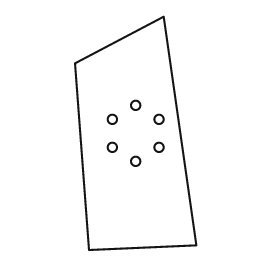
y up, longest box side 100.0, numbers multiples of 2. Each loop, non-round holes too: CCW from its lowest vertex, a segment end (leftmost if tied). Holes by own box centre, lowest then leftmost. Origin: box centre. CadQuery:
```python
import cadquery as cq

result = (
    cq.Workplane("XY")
    .moveTo(-20.0, -50.0)
    .lineTo(26.0, -48.0)
    .lineTo(12.0, 50.0)
    .lineTo(-26.0, 30.0)
    .close()
    .moveTo(0.0, -12.0)
    .circle(2.0)
    .moveTo(-10.0, -6.0)
    .circle(2.0)
    .moveTo(10.0, -6.0)
    .circle(2.0)
    .moveTo(-10.0, 6.0)
    .circle(2.0)
    .moveTo(10.0, 6.0)
    .circle(2.0)
    .moveTo(0.0, 12.0)
    .circle(2.0)
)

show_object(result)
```